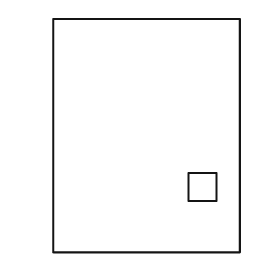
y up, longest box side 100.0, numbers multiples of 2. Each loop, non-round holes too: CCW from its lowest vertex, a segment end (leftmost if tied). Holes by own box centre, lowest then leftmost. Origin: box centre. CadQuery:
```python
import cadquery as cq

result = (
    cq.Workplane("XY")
    .moveTo(-40.0, -50.0)
    .lineTo(40.0, -50.0)
    .lineTo(40.0, 50.0)
    .lineTo(-40.0, 50.0)
    .close()
    .moveTo(18.0, -28.0)
    .lineTo(30.0, -28.0)
    .lineTo(30.0, -16.0)
    .lineTo(18.0, -16.0)
    .close()
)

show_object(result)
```